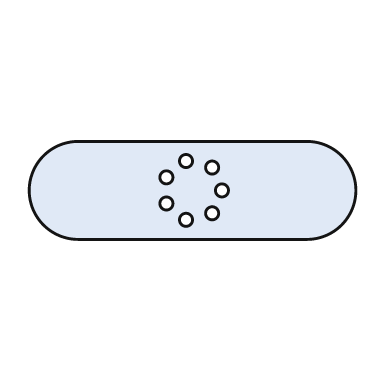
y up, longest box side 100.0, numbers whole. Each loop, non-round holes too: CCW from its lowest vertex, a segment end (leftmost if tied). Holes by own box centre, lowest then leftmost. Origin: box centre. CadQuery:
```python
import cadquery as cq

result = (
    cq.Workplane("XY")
    .moveTo(-35.0, -15.0)
    .lineTo(35.0, -15.0)
    .threePointArc((50.0, 0.0), (35.0, 15.0))
    .lineTo(-35.0, 15.0)
    .threePointArc((-50.0, 0.0), (-35.0, -15.0))
    .close()
    .moveTo(-2.0, -9.0)
    .circle(2.0)
    .moveTo(6.0, -7.0)
    .circle(2.0)
    .moveTo(-8.0, -4.0)
    .circle(2.0)
    .moveTo(9.0, 0.0)
    .circle(2.0)
    .moveTo(-8.0, 4.0)
    .circle(2.0)
    .moveTo(6.0, 7.0)
    .circle(2.0)
    .moveTo(-2.0, 9.0)
    .circle(2.0)
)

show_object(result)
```